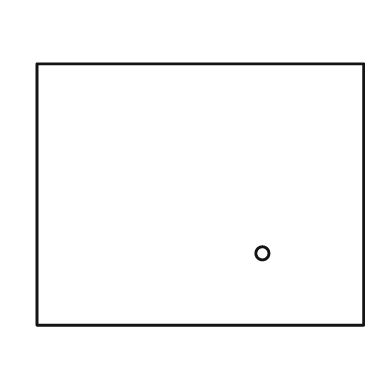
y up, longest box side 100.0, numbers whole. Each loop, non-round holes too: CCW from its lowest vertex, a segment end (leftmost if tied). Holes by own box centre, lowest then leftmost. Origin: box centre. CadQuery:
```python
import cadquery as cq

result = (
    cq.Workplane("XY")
    .moveTo(-50.0, -40.0)
    .lineTo(50.0, -40.0)
    .lineTo(50.0, 40.0)
    .lineTo(-50.0, 40.0)
    .close()
    .moveTo(19.0, -18.0)
    .circle(2.0)
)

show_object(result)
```